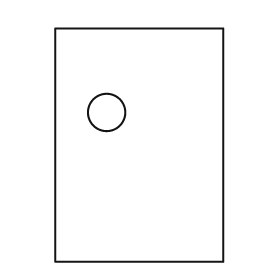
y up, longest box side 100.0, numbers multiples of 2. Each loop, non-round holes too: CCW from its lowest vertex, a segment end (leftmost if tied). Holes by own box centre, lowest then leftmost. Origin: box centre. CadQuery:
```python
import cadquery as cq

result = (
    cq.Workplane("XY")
    .moveTo(-36.0, -50.0)
    .lineTo(36.0, -50.0)
    .lineTo(36.0, 50.0)
    .lineTo(-36.0, 50.0)
    .close()
    .moveTo(-14.0, 14.0)
    .circle(8.0)
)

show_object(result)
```